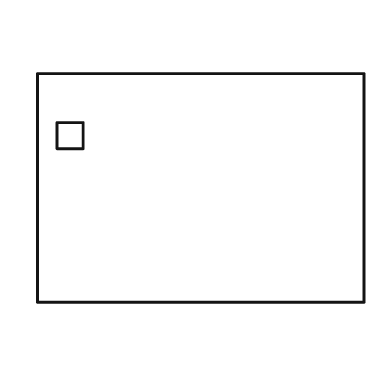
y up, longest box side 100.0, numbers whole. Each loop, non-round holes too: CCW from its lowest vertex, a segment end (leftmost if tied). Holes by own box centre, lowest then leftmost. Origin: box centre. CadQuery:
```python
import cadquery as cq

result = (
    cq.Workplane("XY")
    .moveTo(-50.0, -35.0)
    .lineTo(50.0, -35.0)
    .lineTo(50.0, 35.0)
    .lineTo(-50.0, 35.0)
    .close()
    .moveTo(-44.0, 12.0)
    .lineTo(-36.0, 12.0)
    .lineTo(-36.0, 20.0)
    .lineTo(-44.0, 20.0)
    .close()
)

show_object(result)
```